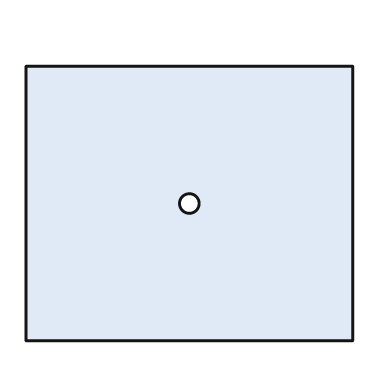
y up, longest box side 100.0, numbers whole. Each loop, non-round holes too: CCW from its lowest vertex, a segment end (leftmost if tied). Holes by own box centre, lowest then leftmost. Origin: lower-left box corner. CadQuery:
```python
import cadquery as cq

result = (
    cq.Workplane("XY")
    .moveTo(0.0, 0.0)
    .lineTo(100.0, 0.0)
    .lineTo(100.0, 84.0)
    .lineTo(0.0, 84.0)
    .close()
    .moveTo(50.0, 42.0)
    .circle(3.0)
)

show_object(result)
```